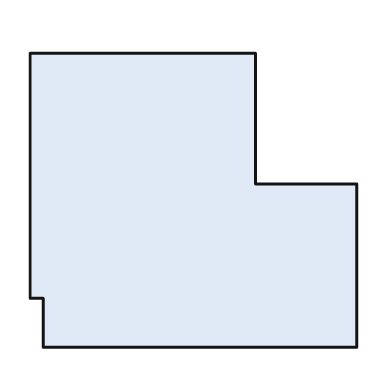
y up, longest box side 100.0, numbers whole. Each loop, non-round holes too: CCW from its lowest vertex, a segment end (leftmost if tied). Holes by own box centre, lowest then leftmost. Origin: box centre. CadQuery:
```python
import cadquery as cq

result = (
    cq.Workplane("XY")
    .moveTo(-46.0, -45.0)
    .lineTo(50.0, -45.0)
    .lineTo(50.0, 5.0)
    .lineTo(19.0, 5.0)
    .lineTo(19.0, 45.0)
    .lineTo(-50.0, 45.0)
    .lineTo(-50.0, -30.0)
    .lineTo(-46.0, -30.0)
    .close()
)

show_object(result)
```